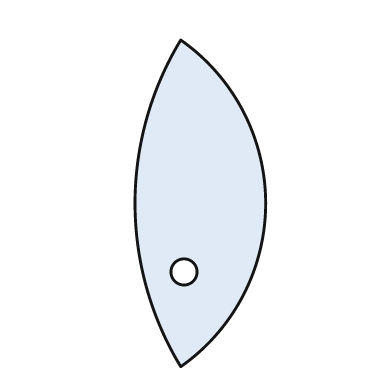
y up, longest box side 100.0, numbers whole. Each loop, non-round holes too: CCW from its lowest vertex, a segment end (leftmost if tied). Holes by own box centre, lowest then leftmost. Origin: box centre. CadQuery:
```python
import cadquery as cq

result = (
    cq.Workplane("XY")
    .moveTo(-6.0, -50.0)
    .threePointArc((20.0, 0.0), (-6.0, 50.0))
    .threePointArc((-20.0, 0.0), (-6.0, -50.0))
    .close()
    .moveTo(-5.0, -21.0)
    .circle(4.0)
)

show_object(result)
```